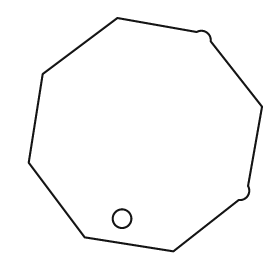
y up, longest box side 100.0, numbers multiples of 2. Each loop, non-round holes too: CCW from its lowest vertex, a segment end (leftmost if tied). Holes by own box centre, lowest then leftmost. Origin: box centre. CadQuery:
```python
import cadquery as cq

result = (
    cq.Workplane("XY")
    .moveTo(12.0, -50.0)
    .lineTo(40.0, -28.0)
    .threePointArc((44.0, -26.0), (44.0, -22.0))
    .lineTo(50.0, 12.0)
    .lineTo(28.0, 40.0)
    .threePointArc((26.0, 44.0), (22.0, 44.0))
    .lineTo(-12.0, 50.0)
    .lineTo(-44.0, 26.0)
    .lineTo(-50.0, -12.0)
    .lineTo(-26.0, -44.0)
    .close()
    .moveTo(-10.0, -36.0)
    .circle(4.0)
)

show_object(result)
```